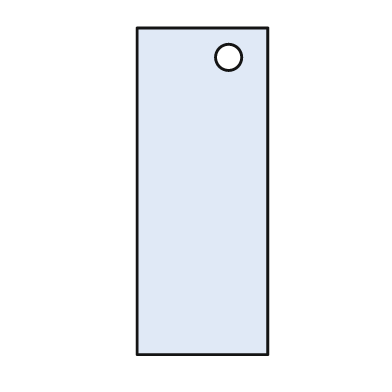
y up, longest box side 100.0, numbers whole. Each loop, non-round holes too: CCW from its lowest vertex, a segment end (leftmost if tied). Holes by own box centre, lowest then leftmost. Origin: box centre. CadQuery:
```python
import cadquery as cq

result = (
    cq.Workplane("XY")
    .moveTo(-20.0, -50.0)
    .lineTo(20.0, -50.0)
    .lineTo(20.0, 50.0)
    .lineTo(-20.0, 50.0)
    .close()
    .moveTo(8.0, 41.0)
    .circle(4.0)
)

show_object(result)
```